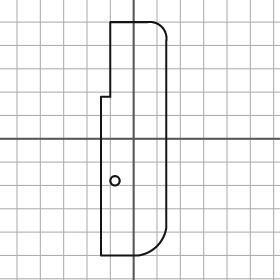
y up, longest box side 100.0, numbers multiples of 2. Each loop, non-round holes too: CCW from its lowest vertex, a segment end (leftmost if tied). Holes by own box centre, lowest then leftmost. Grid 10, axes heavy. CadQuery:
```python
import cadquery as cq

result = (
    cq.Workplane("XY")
    .moveTo(-14.0, -50.0)
    .lineTo(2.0, -50.0)
    .threePointArc((10.0, -46.0), (14.0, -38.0))
    .lineTo(14.0, 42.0)
    .threePointArc((12.0, 48.0), (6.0, 50.0))
    .lineTo(-10.0, 50.0)
    .lineTo(-10.0, 18.0)
    .lineTo(-14.0, 18.0)
    .close()
    .moveTo(-8.0, -18.0)
    .circle(2.0)
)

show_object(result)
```